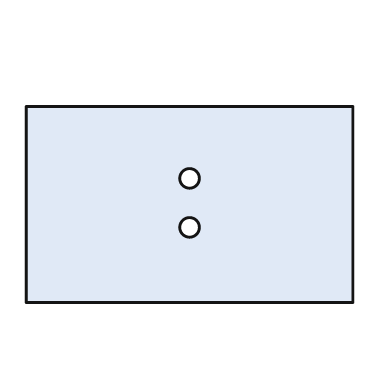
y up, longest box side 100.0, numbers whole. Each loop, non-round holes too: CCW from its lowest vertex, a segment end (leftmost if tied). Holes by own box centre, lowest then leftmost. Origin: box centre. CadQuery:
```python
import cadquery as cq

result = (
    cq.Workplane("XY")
    .moveTo(-50.0, -30.0)
    .lineTo(50.0, -30.0)
    .lineTo(50.0, 30.0)
    .lineTo(-50.0, 30.0)
    .close()
    .moveTo(0.0, -7.0)
    .circle(3.0)
    .moveTo(0.0, 8.0)
    .circle(3.0)
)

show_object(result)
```